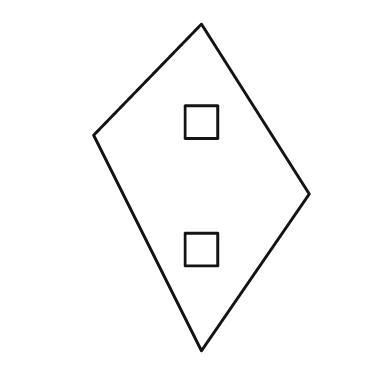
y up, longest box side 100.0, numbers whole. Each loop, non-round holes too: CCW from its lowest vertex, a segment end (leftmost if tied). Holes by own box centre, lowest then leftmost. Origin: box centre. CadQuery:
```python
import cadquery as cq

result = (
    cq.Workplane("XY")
    .moveTo(0.0, -50.0)
    .lineTo(33.0, -2.0)
    .lineTo(0.0, 50.0)
    .lineTo(-33.0, 16.0)
    .close()
    .moveTo(-5.0, -24.0)
    .lineTo(5.0, -24.0)
    .lineTo(5.0, -14.0)
    .lineTo(-5.0, -14.0)
    .close()
    .moveTo(-5.0, 15.0)
    .lineTo(5.0, 15.0)
    .lineTo(5.0, 25.0)
    .lineTo(-5.0, 25.0)
    .close()
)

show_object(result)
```